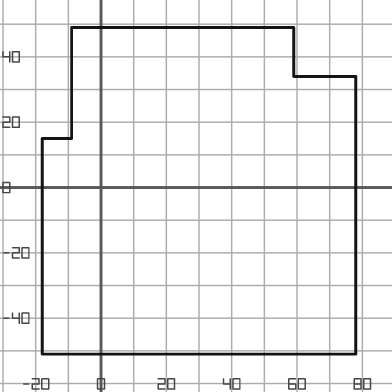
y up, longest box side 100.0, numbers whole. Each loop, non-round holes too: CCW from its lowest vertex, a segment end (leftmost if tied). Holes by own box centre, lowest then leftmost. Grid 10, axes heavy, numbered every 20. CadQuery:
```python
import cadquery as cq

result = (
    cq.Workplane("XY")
    .moveTo(-18.0, -51.0)
    .lineTo(78.0, -51.0)
    .lineTo(78.0, 34.0)
    .lineTo(59.0, 34.0)
    .lineTo(59.0, 49.0)
    .lineTo(-9.0, 49.0)
    .lineTo(-9.0, 15.0)
    .lineTo(-18.0, 15.0)
    .close()
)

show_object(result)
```